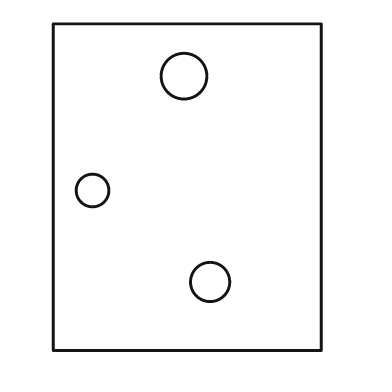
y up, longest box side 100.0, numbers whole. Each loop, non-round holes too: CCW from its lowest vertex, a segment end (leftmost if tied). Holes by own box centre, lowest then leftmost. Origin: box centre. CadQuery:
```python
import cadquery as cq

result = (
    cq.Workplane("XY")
    .moveTo(-41.0, -50.0)
    .lineTo(41.0, -50.0)
    .lineTo(41.0, 50.0)
    .lineTo(-41.0, 50.0)
    .close()
    .moveTo(7.0, -29.0)
    .circle(6.0)
    .moveTo(-29.0, -1.0)
    .circle(5.0)
    .moveTo(-1.0, 34.0)
    .circle(7.0)
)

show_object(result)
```